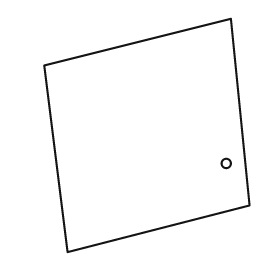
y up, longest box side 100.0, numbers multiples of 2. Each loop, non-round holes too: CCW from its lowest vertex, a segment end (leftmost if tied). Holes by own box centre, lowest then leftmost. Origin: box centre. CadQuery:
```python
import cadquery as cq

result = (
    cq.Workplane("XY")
    .moveTo(-34.0, -50.0)
    .lineTo(44.0, -30.0)
    .lineTo(36.0, 50.0)
    .lineTo(-44.0, 30.0)
    .close()
    .moveTo(34.0, -12.0)
    .circle(2.0)
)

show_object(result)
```